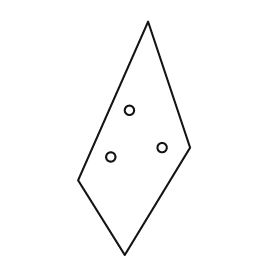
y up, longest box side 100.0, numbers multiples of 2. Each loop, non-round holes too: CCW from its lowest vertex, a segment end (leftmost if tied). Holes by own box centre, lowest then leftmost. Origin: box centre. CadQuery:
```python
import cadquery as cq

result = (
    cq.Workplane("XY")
    .moveTo(-4.0, -50.0)
    .lineTo(24.0, -4.0)
    .lineTo(6.0, 50.0)
    .lineTo(-24.0, -18.0)
    .close()
    .moveTo(-10.0, -8.0)
    .circle(2.0)
    .moveTo(12.0, -4.0)
    .circle(2.0)
    .moveTo(-2.0, 12.0)
    .circle(2.0)
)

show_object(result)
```